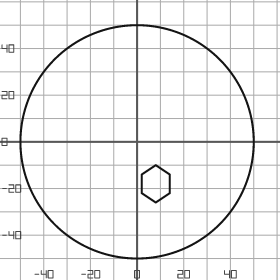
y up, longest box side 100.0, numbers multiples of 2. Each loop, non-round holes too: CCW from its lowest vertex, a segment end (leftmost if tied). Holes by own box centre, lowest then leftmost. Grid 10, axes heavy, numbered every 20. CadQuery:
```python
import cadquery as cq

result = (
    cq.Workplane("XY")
    .moveTo(0.0, 0.0)
    .circle(50.0)
    .moveTo(8.0, -26.0)
    .lineTo(14.0, -22.0)
    .lineTo(14.0, -14.0)
    .lineTo(8.0, -10.0)
    .lineTo(2.0, -14.0)
    .lineTo(2.0, -22.0)
    .close()
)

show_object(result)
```